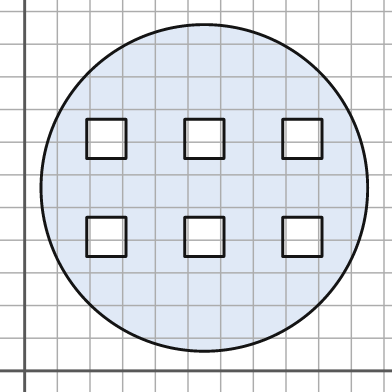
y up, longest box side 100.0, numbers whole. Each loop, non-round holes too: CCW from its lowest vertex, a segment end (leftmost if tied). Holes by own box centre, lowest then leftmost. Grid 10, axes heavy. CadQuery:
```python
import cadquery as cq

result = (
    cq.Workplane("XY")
    .moveTo(55.0, 56.0)
    .circle(50.0)
    .moveTo(19.0, 35.0)
    .lineTo(31.0, 35.0)
    .lineTo(31.0, 47.0)
    .lineTo(19.0, 47.0)
    .close()
    .moveTo(49.0, 35.0)
    .lineTo(61.0, 35.0)
    .lineTo(61.0, 47.0)
    .lineTo(49.0, 47.0)
    .close()
    .moveTo(79.0, 35.0)
    .lineTo(91.0, 35.0)
    .lineTo(91.0, 47.0)
    .lineTo(79.0, 47.0)
    .close()
    .moveTo(19.0, 65.0)
    .lineTo(31.0, 65.0)
    .lineTo(31.0, 77.0)
    .lineTo(19.0, 77.0)
    .close()
    .moveTo(49.0, 65.0)
    .lineTo(61.0, 65.0)
    .lineTo(61.0, 77.0)
    .lineTo(49.0, 77.0)
    .close()
    .moveTo(79.0, 65.0)
    .lineTo(91.0, 65.0)
    .lineTo(91.0, 77.0)
    .lineTo(79.0, 77.0)
    .close()
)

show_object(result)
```